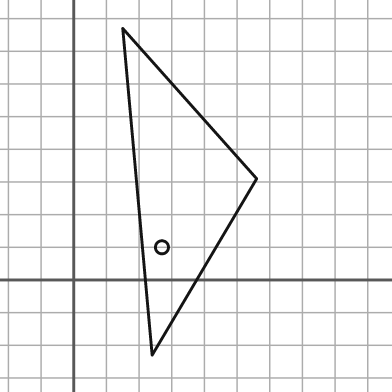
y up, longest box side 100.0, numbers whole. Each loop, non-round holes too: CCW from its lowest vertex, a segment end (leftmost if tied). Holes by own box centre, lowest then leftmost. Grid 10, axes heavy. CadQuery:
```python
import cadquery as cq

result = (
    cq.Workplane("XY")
    .moveTo(24.0, -23.0)
    .lineTo(56.0, 31.0)
    .lineTo(15.0, 77.0)
    .close()
    .moveTo(27.0, 10.0)
    .circle(2.0)
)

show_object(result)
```